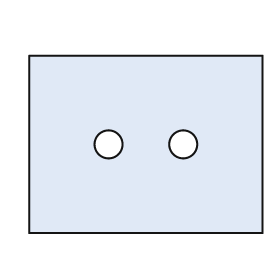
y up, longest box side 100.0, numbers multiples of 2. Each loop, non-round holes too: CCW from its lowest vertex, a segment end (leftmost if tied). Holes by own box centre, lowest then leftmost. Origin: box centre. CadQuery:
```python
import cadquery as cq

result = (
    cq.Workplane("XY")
    .moveTo(-50.0, -38.0)
    .lineTo(50.0, -38.0)
    .lineTo(50.0, 38.0)
    .lineTo(-50.0, 38.0)
    .close()
    .moveTo(-16.0, 0.0)
    .circle(6.0)
    .moveTo(16.0, 0.0)
    .circle(6.0)
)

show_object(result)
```